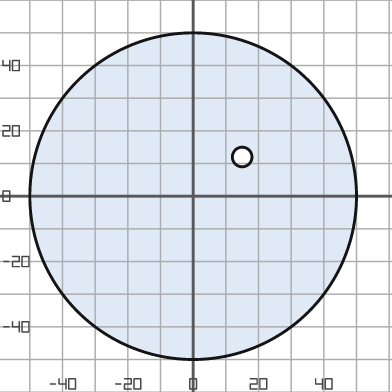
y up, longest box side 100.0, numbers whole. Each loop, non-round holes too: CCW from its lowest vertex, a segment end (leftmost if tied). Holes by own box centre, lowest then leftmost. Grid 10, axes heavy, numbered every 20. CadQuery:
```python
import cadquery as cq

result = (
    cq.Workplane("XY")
    .moveTo(0.0, 0.0)
    .circle(50.0)
    .moveTo(15.0, 12.0)
    .circle(3.0)
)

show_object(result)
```